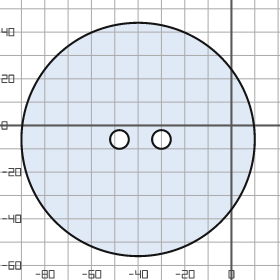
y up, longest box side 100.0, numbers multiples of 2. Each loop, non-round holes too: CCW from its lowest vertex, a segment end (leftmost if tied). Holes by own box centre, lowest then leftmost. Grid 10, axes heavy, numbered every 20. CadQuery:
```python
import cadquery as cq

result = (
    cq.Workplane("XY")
    .moveTo(-40.0, -6.0)
    .circle(50.0)
    .moveTo(-48.0, -6.0)
    .circle(4.0)
    .moveTo(-30.0, -6.0)
    .circle(4.0)
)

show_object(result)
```